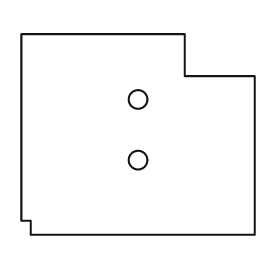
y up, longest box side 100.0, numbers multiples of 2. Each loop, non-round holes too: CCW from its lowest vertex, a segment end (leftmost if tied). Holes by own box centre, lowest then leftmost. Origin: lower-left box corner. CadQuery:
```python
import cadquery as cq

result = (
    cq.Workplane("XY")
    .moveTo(4.0, 0.0)
    .lineTo(100.0, 0.0)
    .lineTo(100.0, 68.0)
    .lineTo(70.0, 68.0)
    .lineTo(70.0, 86.0)
    .lineTo(0.0, 86.0)
    .lineTo(0.0, 6.0)
    .lineTo(4.0, 6.0)
    .close()
    .moveTo(50.0, 32.0)
    .circle(4.0)
    .moveTo(50.0, 58.0)
    .circle(4.0)
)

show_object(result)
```